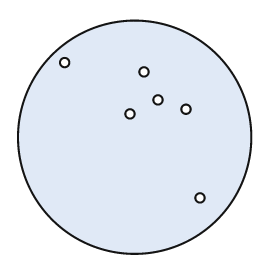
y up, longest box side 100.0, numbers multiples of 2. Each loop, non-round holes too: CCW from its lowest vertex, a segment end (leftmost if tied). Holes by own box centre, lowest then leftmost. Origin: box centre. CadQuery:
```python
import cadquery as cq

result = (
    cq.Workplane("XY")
    .moveTo(0.0, 0.0)
    .circle(50.0)
    .moveTo(28.0, -26.0)
    .circle(2.0)
    .moveTo(-2.0, 10.0)
    .circle(2.0)
    .moveTo(22.0, 12.0)
    .circle(2.0)
    .moveTo(10.0, 16.0)
    .circle(2.0)
    .moveTo(4.0, 28.0)
    .circle(2.0)
    .moveTo(-30.0, 32.0)
    .circle(2.0)
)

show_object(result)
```